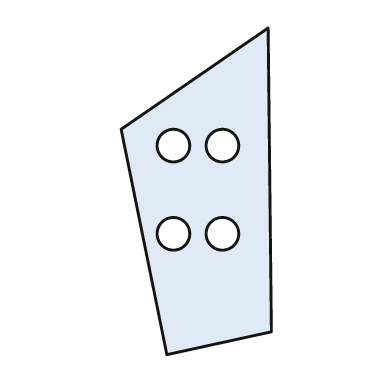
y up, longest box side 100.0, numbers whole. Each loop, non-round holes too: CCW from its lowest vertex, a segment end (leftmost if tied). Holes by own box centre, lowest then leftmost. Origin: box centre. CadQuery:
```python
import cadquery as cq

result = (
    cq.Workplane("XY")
    .moveTo(-9.0, -50.0)
    .lineTo(23.0, -43.0)
    .lineTo(22.0, 50.0)
    .lineTo(-23.0, 19.0)
    .close()
    .moveTo(-7.0, -13.0)
    .circle(5.0)
    .moveTo(8.0, -13.0)
    .circle(5.0)
    .moveTo(-7.0, 14.0)
    .circle(5.0)
    .moveTo(8.0, 14.0)
    .circle(5.0)
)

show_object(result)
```